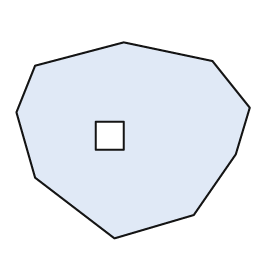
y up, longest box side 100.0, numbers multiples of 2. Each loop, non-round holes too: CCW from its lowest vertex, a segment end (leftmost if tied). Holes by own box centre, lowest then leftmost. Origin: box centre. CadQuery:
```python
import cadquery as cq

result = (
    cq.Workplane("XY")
    .moveTo(-8.0, -42.0)
    .lineTo(26.0, -32.0)
    .lineTo(44.0, -6.0)
    .lineTo(50.0, 14.0)
    .lineTo(34.0, 34.0)
    .lineTo(-4.0, 42.0)
    .lineTo(-42.0, 32.0)
    .lineTo(-50.0, 12.0)
    .lineTo(-42.0, -16.0)
    .close()
    .moveTo(-16.0, -4.0)
    .lineTo(-4.0, -4.0)
    .lineTo(-4.0, 8.0)
    .lineTo(-16.0, 8.0)
    .close()
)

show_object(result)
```